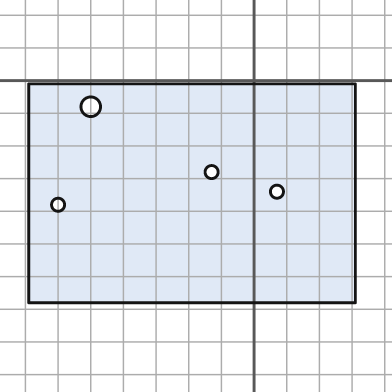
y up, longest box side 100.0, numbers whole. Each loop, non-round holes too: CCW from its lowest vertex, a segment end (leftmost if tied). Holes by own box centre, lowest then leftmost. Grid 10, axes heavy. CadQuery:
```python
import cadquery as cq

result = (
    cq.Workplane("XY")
    .moveTo(-69.0, -68.0)
    .lineTo(31.0, -68.0)
    .lineTo(31.0, -1.0)
    .lineTo(-69.0, -1.0)
    .close()
    .moveTo(-60.0, -38.0)
    .circle(2.0)
    .moveTo(7.0, -34.0)
    .circle(2.0)
    .moveTo(-13.0, -28.0)
    .circle(2.0)
    .moveTo(-50.0, -8.0)
    .circle(3.0)
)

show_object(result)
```